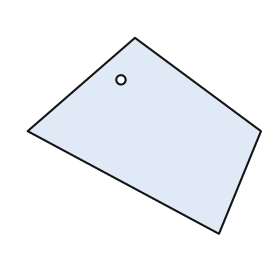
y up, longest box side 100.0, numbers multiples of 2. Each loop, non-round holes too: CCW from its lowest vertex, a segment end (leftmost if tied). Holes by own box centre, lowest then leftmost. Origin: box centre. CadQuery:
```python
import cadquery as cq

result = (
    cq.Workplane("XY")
    .moveTo(32.0, -42.0)
    .lineTo(50.0, 2.0)
    .lineTo(-4.0, 42.0)
    .lineTo(-50.0, 2.0)
    .close()
    .moveTo(-10.0, 24.0)
    .circle(2.0)
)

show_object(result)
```